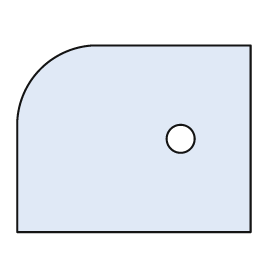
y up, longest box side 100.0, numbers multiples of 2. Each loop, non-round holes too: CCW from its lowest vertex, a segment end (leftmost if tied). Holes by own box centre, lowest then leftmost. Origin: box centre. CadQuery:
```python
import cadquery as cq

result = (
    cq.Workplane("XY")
    .moveTo(-50.0, -40.0)
    .lineTo(50.0, -40.0)
    .lineTo(50.0, 40.0)
    .lineTo(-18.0, 40.0)
    .threePointArc((-40.0, 30.0), (-50.0, 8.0))
    .close()
    .moveTo(20.0, 0.0)
    .circle(6.0)
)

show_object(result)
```